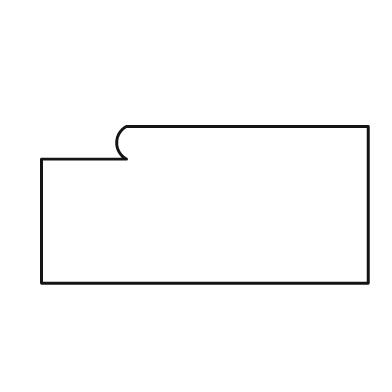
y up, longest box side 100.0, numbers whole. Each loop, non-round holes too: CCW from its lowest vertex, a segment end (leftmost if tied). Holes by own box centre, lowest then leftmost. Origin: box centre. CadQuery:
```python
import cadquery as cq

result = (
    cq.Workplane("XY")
    .moveTo(-50.0, -24.0)
    .lineTo(50.0, -24.0)
    .lineTo(50.0, 24.0)
    .lineTo(-24.0, 24.0)
    .threePointArc((-27.0, 19.0), (-24.0, 14.0))
    .lineTo(-50.0, 14.0)
    .close()
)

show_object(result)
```